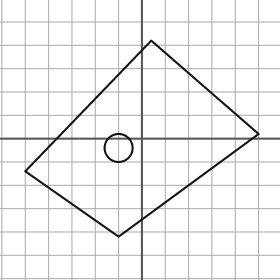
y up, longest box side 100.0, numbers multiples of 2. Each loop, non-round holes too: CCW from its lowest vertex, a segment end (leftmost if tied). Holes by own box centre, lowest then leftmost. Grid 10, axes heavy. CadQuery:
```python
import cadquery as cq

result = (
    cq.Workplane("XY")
    .moveTo(-10.0, -42.0)
    .lineTo(50.0, 2.0)
    .lineTo(4.0, 42.0)
    .lineTo(-50.0, -14.0)
    .close()
    .moveTo(-10.0, -4.0)
    .circle(6.0)
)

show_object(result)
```